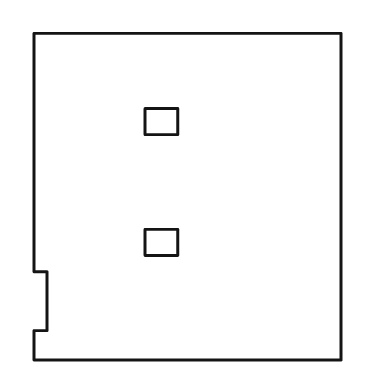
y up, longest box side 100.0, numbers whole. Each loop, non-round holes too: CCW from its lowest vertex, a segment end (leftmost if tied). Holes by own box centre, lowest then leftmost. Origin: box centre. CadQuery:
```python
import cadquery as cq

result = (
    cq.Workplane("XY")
    .moveTo(-47.0, -50.0)
    .lineTo(47.0, -50.0)
    .lineTo(47.0, 50.0)
    .lineTo(-47.0, 50.0)
    .lineTo(-47.0, -23.0)
    .lineTo(-43.0, -23.0)
    .lineTo(-43.0, -41.0)
    .lineTo(-47.0, -41.0)
    .close()
    .moveTo(-13.0, -18.0)
    .lineTo(-3.0, -18.0)
    .lineTo(-3.0, -10.0)
    .lineTo(-13.0, -10.0)
    .close()
    .moveTo(-13.0, 19.0)
    .lineTo(-3.0, 19.0)
    .lineTo(-3.0, 27.0)
    .lineTo(-13.0, 27.0)
    .close()
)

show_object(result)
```